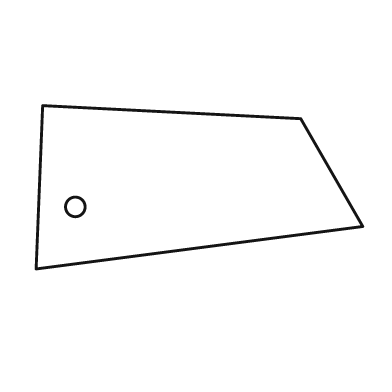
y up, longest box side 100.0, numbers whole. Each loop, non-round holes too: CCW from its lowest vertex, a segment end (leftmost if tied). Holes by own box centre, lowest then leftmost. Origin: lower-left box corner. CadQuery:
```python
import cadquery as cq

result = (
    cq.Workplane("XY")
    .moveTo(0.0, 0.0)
    .lineTo(100.0, 13.0)
    .lineTo(81.0, 46.0)
    .lineTo(2.0, 50.0)
    .close()
    .moveTo(12.0, 19.0)
    .circle(3.0)
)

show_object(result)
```